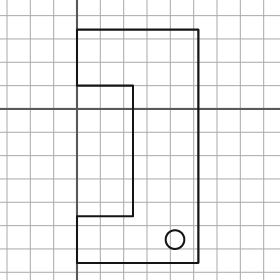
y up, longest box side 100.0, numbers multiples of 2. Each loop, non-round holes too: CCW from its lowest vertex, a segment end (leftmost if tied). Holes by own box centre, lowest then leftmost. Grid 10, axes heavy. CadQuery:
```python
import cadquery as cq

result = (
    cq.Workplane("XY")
    .moveTo(0.0, -66.0)
    .lineTo(52.0, -66.0)
    .lineTo(52.0, 34.0)
    .lineTo(0.0, 34.0)
    .lineTo(0.0, 10.0)
    .lineTo(24.0, 10.0)
    .lineTo(24.0, -46.0)
    .lineTo(0.0, -46.0)
    .close()
    .moveTo(42.0, -56.0)
    .circle(4.0)
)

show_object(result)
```